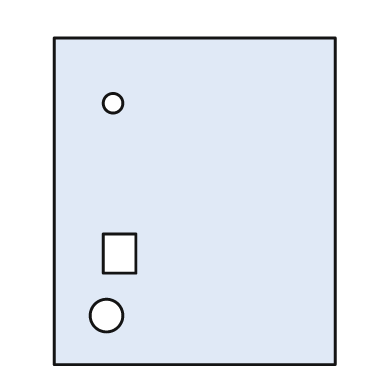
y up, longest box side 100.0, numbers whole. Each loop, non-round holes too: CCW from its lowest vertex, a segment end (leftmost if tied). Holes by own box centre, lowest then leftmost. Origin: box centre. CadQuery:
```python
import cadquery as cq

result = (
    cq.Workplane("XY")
    .moveTo(-43.0, -50.0)
    .lineTo(43.0, -50.0)
    .lineTo(43.0, 50.0)
    .lineTo(-43.0, 50.0)
    .close()
    .moveTo(-27.0, -35.0)
    .circle(5.0)
    .moveTo(-28.0, -22.0)
    .lineTo(-18.0, -22.0)
    .lineTo(-18.0, -10.0)
    .lineTo(-28.0, -10.0)
    .close()
    .moveTo(-25.0, 30.0)
    .circle(3.0)
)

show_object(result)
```